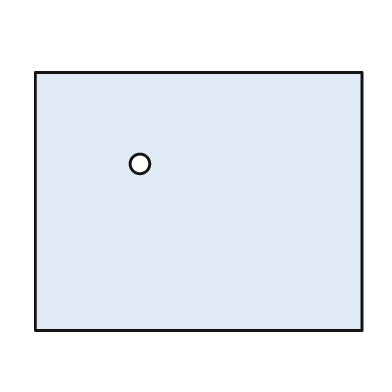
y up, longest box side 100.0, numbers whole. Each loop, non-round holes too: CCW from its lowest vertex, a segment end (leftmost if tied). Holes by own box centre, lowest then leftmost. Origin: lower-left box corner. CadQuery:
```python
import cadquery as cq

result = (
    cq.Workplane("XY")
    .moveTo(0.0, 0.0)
    .lineTo(100.0, 0.0)
    .lineTo(100.0, 79.0)
    .lineTo(0.0, 79.0)
    .close()
    .moveTo(32.0, 51.0)
    .circle(3.0)
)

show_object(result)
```